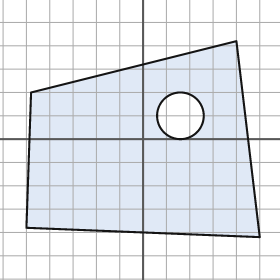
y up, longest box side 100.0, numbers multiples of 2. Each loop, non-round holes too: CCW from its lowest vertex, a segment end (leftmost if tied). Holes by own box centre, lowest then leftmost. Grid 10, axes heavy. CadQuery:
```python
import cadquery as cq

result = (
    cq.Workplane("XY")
    .moveTo(50.0, -42.0)
    .lineTo(40.0, 42.0)
    .lineTo(-48.0, 20.0)
    .lineTo(-50.0, -38.0)
    .close()
    .moveTo(16.0, 10.0)
    .circle(10.0)
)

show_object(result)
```